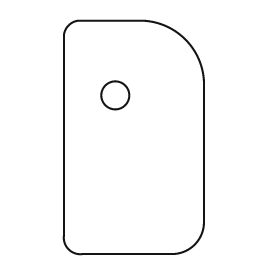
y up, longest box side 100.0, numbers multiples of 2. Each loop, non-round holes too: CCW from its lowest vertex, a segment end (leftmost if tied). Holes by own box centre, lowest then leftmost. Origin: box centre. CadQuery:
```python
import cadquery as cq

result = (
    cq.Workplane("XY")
    .moveTo(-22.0, -50.0)
    .lineTo(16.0, -50.0)
    .threePointArc((26.0, -46.0), (30.0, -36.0))
    .lineTo(30.0, 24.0)
    .threePointArc((22.0, 42.0), (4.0, 50.0))
    .lineTo(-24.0, 50.0)
    .threePointArc((-28.0, 48.0), (-30.0, 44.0))
    .lineTo(-30.0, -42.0)
    .threePointArc((-28.0, -48.0), (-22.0, -50.0))
    .close()
    .moveTo(-8.0, 18.0)
    .circle(6.0)
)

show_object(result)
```